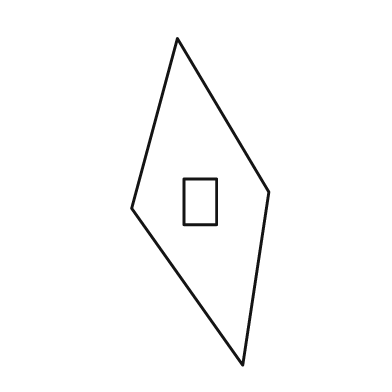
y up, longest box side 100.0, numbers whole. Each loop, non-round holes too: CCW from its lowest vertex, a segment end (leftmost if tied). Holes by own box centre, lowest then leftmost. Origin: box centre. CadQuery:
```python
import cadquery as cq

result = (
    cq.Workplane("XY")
    .moveTo(13.0, -50.0)
    .lineTo(21.0, 3.0)
    .lineTo(-7.0, 50.0)
    .lineTo(-21.0, -2.0)
    .close()
    .moveTo(-5.0, -7.0)
    .lineTo(5.0, -7.0)
    .lineTo(5.0, 7.0)
    .lineTo(-5.0, 7.0)
    .close()
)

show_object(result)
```